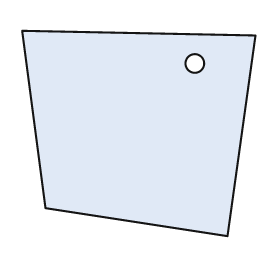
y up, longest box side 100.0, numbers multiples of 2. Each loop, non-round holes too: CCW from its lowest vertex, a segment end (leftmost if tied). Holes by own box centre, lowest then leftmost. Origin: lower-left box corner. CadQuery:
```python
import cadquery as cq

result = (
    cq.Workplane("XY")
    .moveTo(88.0, 0.0)
    .lineTo(100.0, 86.0)
    .lineTo(0.0, 88.0)
    .lineTo(10.0, 12.0)
    .close()
    .moveTo(74.0, 74.0)
    .circle(4.0)
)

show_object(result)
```